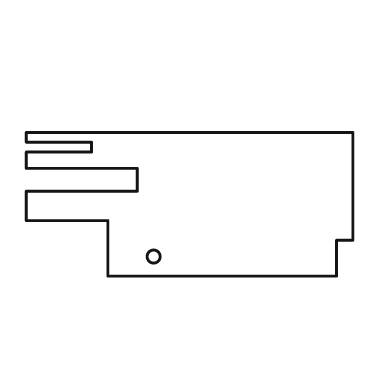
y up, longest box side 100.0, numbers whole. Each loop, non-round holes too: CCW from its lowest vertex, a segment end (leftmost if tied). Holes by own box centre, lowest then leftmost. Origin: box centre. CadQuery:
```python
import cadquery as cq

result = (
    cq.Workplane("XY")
    .moveTo(-25.0, -22.0)
    .lineTo(45.0, -22.0)
    .lineTo(45.0, -11.0)
    .lineTo(50.0, -11.0)
    .lineTo(50.0, 22.0)
    .lineTo(-50.0, 22.0)
    .lineTo(-50.0, 19.0)
    .lineTo(-30.0, 19.0)
    .lineTo(-30.0, 16.0)
    .lineTo(-50.0, 16.0)
    .lineTo(-50.0, 11.0)
    .lineTo(-16.0, 11.0)
    .lineTo(-16.0, 4.0)
    .lineTo(-50.0, 4.0)
    .lineTo(-50.0, -5.0)
    .lineTo(-25.0, -5.0)
    .close()
    .moveTo(-11.0, -16.0)
    .circle(2.0)
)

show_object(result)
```